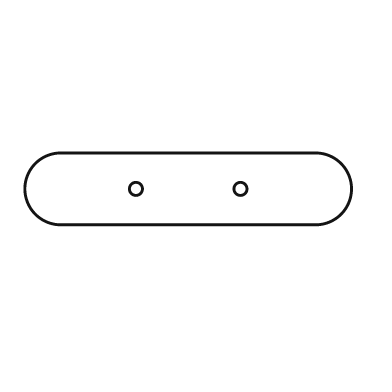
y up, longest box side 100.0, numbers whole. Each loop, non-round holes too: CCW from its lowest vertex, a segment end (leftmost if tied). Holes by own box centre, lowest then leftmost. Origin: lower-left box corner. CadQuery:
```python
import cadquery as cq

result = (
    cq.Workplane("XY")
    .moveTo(11.0, 0.0)
    .lineTo(89.0, 0.0)
    .threePointArc((100.0, 11.0), (89.0, 22.0))
    .lineTo(11.0, 22.0)
    .threePointArc((0.0, 11.0), (11.0, 0.0))
    .close()
    .moveTo(34.0, 11.0)
    .circle(2.0)
    .moveTo(66.0, 11.0)
    .circle(2.0)
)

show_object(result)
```